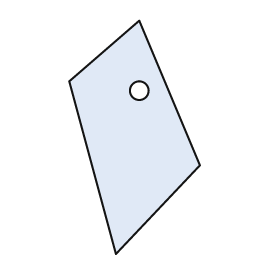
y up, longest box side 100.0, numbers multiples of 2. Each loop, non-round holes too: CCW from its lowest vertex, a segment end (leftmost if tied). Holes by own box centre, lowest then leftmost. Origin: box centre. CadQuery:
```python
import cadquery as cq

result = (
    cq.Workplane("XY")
    .moveTo(-8.0, -50.0)
    .lineTo(28.0, -12.0)
    .lineTo(2.0, 50.0)
    .lineTo(-28.0, 24.0)
    .close()
    .moveTo(2.0, 20.0)
    .circle(4.0)
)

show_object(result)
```